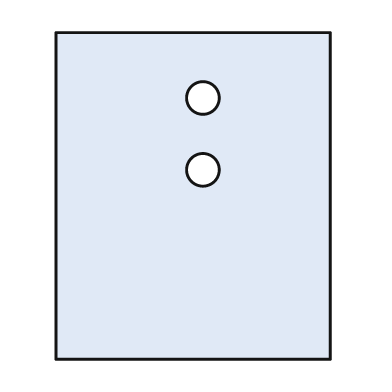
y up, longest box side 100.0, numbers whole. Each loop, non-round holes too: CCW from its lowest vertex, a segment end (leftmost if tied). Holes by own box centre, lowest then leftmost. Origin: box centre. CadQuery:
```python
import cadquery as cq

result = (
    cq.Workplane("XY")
    .moveTo(-42.0, -50.0)
    .lineTo(42.0, -50.0)
    .lineTo(42.0, 50.0)
    .lineTo(-42.0, 50.0)
    .close()
    .moveTo(3.0, 8.0)
    .circle(5.0)
    .moveTo(3.0, 30.0)
    .circle(5.0)
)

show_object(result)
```